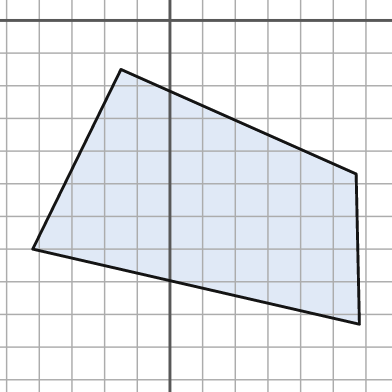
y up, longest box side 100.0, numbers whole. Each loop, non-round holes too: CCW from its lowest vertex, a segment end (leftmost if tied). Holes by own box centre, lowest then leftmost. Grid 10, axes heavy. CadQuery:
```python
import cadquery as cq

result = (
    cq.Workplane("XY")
    .moveTo(58.0, -93.0)
    .lineTo(57.0, -47.0)
    .lineTo(-15.0, -15.0)
    .lineTo(-42.0, -70.0)
    .close()
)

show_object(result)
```